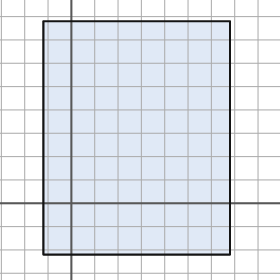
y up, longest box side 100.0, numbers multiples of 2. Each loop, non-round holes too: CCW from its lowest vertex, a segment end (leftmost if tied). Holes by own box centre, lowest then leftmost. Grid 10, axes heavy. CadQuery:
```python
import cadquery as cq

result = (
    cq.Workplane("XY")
    .moveTo(-12.0, -22.0)
    .lineTo(68.0, -22.0)
    .lineTo(68.0, 78.0)
    .lineTo(-12.0, 78.0)
    .close()
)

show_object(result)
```